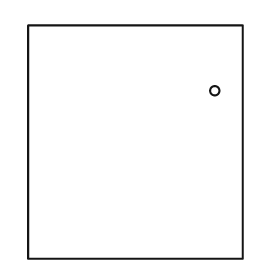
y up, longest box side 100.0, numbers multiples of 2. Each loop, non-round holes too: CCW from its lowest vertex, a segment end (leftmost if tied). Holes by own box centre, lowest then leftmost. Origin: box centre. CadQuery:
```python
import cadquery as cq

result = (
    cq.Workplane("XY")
    .moveTo(-46.0, -50.0)
    .lineTo(46.0, -50.0)
    .lineTo(46.0, 50.0)
    .lineTo(-46.0, 50.0)
    .close()
    .moveTo(34.0, 22.0)
    .circle(2.0)
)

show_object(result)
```